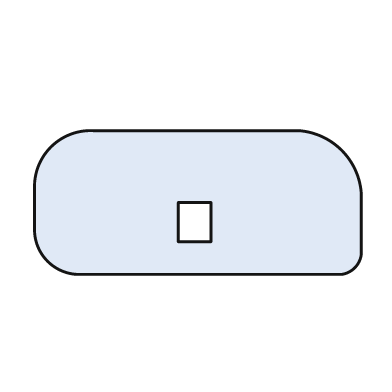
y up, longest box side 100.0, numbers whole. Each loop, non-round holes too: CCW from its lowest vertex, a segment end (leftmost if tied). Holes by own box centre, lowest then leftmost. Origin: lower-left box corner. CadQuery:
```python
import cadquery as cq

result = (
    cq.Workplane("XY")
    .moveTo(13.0, 0.0)
    .lineTo(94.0, 0.0)
    .threePointArc((98.0, 2.0), (100.0, 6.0))
    .lineTo(100.0, 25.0)
    .threePointArc((94.0, 38.0), (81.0, 44.0))
    .lineTo(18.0, 44.0)
    .threePointArc((5.0, 39.0), (0.0, 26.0))
    .lineTo(0.0, 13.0)
    .threePointArc((4.0, 4.0), (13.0, 0.0))
    .close()
    .moveTo(44.0, 10.0)
    .lineTo(54.0, 10.0)
    .lineTo(54.0, 22.0)
    .lineTo(44.0, 22.0)
    .close()
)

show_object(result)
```